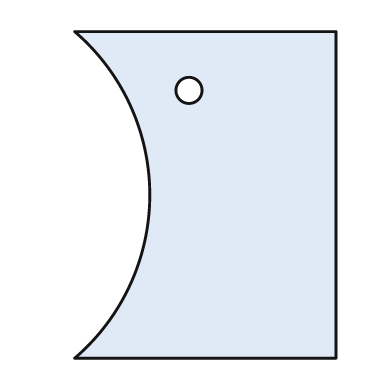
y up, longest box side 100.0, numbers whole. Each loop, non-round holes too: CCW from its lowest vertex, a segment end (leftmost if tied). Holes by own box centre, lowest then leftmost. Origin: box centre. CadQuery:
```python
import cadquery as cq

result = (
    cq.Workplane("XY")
    .moveTo(-40.0, -50.0)
    .lineTo(40.0, -50.0)
    .lineTo(40.0, 50.0)
    .lineTo(-40.0, 50.0)
    .threePointArc((-17.0, 0.0), (-40.0, -50.0))
    .close()
    .moveTo(-5.0, 32.0)
    .circle(4.0)
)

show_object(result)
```